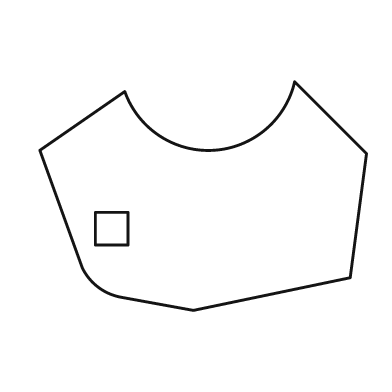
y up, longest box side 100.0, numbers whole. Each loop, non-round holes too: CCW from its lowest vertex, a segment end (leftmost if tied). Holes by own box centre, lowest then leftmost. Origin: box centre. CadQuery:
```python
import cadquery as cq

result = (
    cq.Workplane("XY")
    .moveTo(-3.0, -35.0)
    .lineTo(45.0, -25.0)
    .lineTo(50.0, 13.0)
    .lineTo(28.0, 35.0)
    .threePointArc((3.0, 14.0), (-24.0, 32.0))
    .lineTo(-50.0, 14.0)
    .lineTo(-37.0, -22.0)
    .threePointArc((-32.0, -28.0), (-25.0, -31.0))
    .close()
    .moveTo(-33.0, -15.0)
    .lineTo(-23.0, -15.0)
    .lineTo(-23.0, -5.0)
    .lineTo(-33.0, -5.0)
    .close()
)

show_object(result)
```